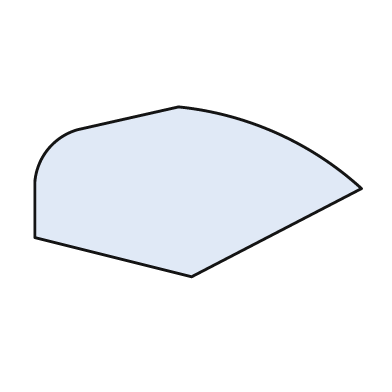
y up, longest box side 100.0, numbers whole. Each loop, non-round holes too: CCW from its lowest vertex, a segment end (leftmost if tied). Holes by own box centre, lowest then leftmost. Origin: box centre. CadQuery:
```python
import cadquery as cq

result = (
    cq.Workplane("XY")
    .moveTo(-2.0, -26.0)
    .lineTo(50.0, 1.0)
    .threePointArc((24.0, 18.0), (-6.0, 26.0))
    .lineTo(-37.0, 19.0)
    .threePointArc((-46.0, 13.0), (-50.0, 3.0))
    .lineTo(-50.0, -14.0)
    .close()
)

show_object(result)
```